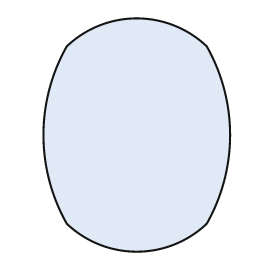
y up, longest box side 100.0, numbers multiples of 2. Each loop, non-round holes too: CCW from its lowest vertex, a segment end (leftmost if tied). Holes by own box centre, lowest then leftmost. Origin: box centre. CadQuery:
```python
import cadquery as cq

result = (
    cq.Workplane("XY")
    .moveTo(-30.0, -38.0)
    .threePointArc((0.0, -50.0), (30.0, -38.0))
    .threePointArc((40.0, 0.0), (30.0, 38.0))
    .threePointArc((0.0, 50.0), (-30.0, 38.0))
    .threePointArc((-40.0, 0.0), (-30.0, -38.0))
    .close()
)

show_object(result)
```